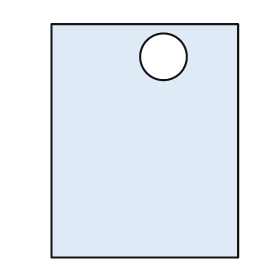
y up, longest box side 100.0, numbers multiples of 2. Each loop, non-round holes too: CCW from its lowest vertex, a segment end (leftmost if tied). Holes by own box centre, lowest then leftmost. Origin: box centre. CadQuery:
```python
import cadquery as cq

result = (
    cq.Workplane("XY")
    .moveTo(-40.0, -50.0)
    .lineTo(40.0, -50.0)
    .lineTo(40.0, 50.0)
    .lineTo(-40.0, 50.0)
    .close()
    .moveTo(8.0, 36.0)
    .circle(10.0)
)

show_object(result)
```